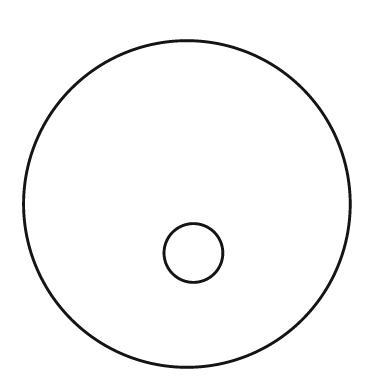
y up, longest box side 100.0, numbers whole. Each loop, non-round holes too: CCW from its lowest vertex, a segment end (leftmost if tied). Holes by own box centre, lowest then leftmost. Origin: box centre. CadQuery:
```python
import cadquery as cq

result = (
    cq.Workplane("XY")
    .moveTo(0.0, 0.0)
    .circle(50.0)
    .moveTo(2.0, -15.0)
    .circle(9.0)
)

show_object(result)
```